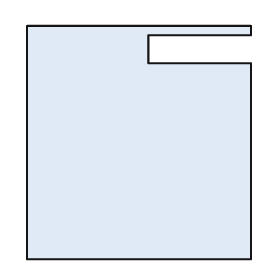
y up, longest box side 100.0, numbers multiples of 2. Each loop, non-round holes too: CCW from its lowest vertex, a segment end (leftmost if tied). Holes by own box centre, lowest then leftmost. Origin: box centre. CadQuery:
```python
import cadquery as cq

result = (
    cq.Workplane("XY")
    .moveTo(-48.0, -50.0)
    .lineTo(48.0, -50.0)
    .lineTo(48.0, 34.0)
    .lineTo(4.0, 34.0)
    .lineTo(4.0, 46.0)
    .lineTo(48.0, 46.0)
    .lineTo(48.0, 50.0)
    .lineTo(-48.0, 50.0)
    .close()
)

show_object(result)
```